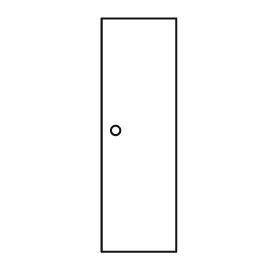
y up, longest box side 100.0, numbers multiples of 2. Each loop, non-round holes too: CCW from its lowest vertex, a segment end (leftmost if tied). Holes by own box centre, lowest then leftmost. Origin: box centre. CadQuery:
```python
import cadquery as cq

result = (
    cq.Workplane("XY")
    .moveTo(-16.0, -50.0)
    .lineTo(16.0, -50.0)
    .lineTo(16.0, 50.0)
    .lineTo(-16.0, 50.0)
    .close()
    .moveTo(-10.0, 2.0)
    .circle(2.0)
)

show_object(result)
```